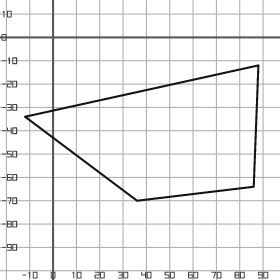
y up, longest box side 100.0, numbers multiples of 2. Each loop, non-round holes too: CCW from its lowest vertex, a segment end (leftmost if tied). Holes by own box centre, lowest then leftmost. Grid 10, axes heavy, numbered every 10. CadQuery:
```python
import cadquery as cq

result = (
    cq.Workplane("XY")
    .moveTo(36.0, -70.0)
    .lineTo(86.0, -64.0)
    .lineTo(88.0, -12.0)
    .lineTo(-12.0, -34.0)
    .close()
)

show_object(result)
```